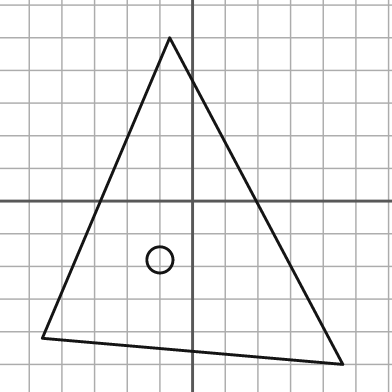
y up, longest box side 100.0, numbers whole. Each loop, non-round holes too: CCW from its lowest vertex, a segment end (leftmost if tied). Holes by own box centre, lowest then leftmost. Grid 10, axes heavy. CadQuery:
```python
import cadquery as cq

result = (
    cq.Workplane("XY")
    .moveTo(46.0, -50.0)
    .lineTo(-7.0, 50.0)
    .lineTo(-46.0, -42.0)
    .close()
    .moveTo(-10.0, -18.0)
    .circle(4.0)
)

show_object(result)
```